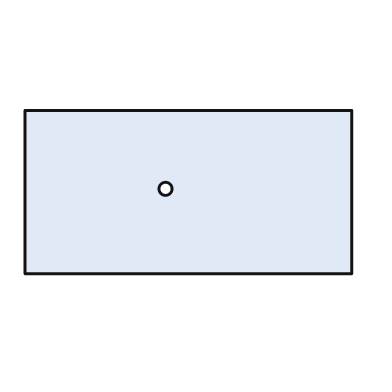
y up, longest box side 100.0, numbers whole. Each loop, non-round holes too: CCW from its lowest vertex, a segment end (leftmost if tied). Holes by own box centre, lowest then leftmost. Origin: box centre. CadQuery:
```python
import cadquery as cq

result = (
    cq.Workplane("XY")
    .moveTo(-50.0, -25.0)
    .lineTo(50.0, -25.0)
    .lineTo(50.0, 25.0)
    .lineTo(-50.0, 25.0)
    .close()
    .moveTo(-7.0, 1.0)
    .circle(2.0)
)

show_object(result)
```